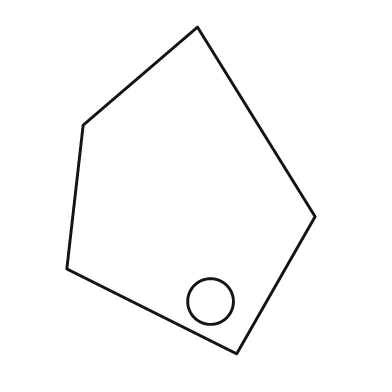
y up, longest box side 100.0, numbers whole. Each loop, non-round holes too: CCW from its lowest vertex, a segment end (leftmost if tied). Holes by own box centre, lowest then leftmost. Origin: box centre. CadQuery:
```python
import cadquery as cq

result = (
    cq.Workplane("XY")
    .moveTo(14.0, -50.0)
    .lineTo(38.0, -8.0)
    .lineTo(2.0, 50.0)
    .lineTo(-33.0, 20.0)
    .lineTo(-38.0, -24.0)
    .close()
    .moveTo(6.0, -34.0)
    .circle(7.0)
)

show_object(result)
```